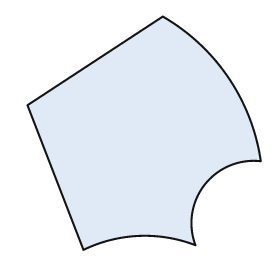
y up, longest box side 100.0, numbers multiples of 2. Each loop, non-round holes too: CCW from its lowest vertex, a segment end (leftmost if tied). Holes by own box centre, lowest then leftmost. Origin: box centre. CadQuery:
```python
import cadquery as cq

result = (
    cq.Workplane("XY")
    .moveTo(-26.0, -50.0)
    .threePointArc((-2.0, -44.0), (22.0, -48.0))
    .threePointArc((26.0, -22.0), (50.0, -12.0))
    .threePointArc((36.0, 24.0), (8.0, 50.0))
    .lineTo(-50.0, 12.0)
    .close()
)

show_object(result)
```